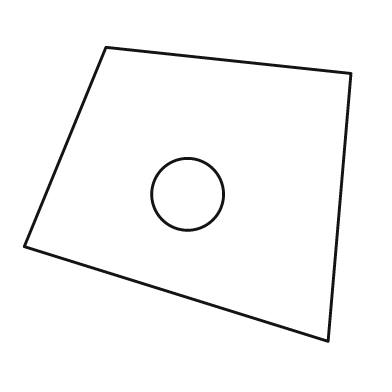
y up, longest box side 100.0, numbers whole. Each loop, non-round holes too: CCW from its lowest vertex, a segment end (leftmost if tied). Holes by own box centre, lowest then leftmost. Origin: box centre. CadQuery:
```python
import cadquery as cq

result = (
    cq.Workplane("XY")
    .moveTo(43.0, -45.0)
    .lineTo(50.0, 37.0)
    .lineTo(-25.0, 45.0)
    .lineTo(-50.0, -16.0)
    .close()
    .moveTo(0.0, 0.0)
    .circle(11.0)
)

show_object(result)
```